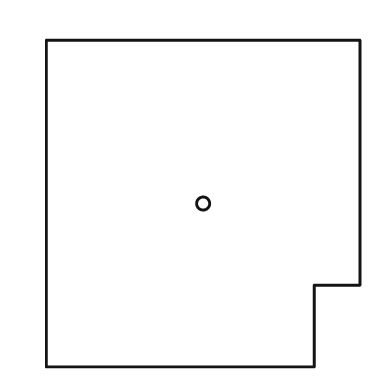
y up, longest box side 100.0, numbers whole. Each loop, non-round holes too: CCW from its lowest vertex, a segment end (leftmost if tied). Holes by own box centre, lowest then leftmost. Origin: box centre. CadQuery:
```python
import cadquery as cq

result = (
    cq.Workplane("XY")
    .moveTo(-48.0, -50.0)
    .lineTo(34.0, -50.0)
    .lineTo(34.0, -25.0)
    .lineTo(48.0, -25.0)
    .lineTo(48.0, 50.0)
    .lineTo(-48.0, 50.0)
    .close()
    .moveTo(0.0, 0.0)
    .circle(2.0)
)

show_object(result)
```